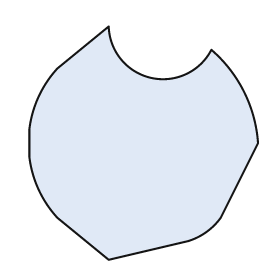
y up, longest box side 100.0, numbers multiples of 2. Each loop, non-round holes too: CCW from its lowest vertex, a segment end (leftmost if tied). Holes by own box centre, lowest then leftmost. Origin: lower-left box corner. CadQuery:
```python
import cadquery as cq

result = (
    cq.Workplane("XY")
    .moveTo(34.0, 0.0)
    .lineTo(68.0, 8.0)
    .threePointArc((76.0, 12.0), (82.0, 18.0))
    .lineTo(98.0, 50.0)
    .threePointArc((92.0, 72.0), (78.0, 90.0))
    .threePointArc((52.0, 78.0), (34.0, 100.0))
    .lineTo(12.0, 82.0)
    .threePointArc((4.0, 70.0), (0.0, 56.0))
    .lineTo(0.0, 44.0)
    .threePointArc((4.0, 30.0), (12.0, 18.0))
    .close()
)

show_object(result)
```